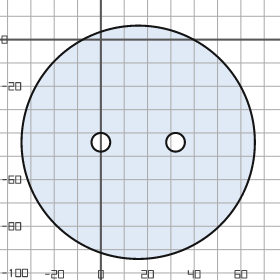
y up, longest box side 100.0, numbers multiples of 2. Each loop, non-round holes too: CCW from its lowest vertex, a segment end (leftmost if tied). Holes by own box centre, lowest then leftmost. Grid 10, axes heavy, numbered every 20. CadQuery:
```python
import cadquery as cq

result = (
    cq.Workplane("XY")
    .moveTo(16.0, -44.0)
    .circle(50.0)
    .moveTo(0.0, -44.0)
    .circle(4.0)
    .moveTo(32.0, -44.0)
    .circle(4.0)
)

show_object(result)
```